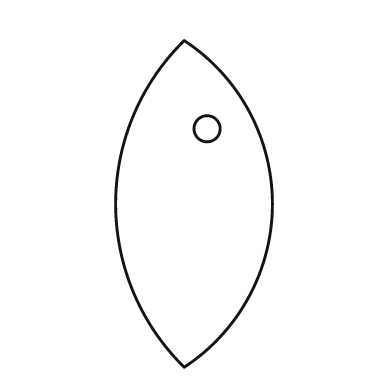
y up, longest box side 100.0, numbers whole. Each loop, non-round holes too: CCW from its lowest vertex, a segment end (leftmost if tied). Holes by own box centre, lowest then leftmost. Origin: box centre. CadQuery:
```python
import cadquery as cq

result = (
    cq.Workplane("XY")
    .moveTo(-3.0, -50.0)
    .threePointArc((24.0, 0.0), (-3.0, 50.0))
    .threePointArc((-24.0, 0.0), (-3.0, -50.0))
    .close()
    .moveTo(4.0, 23.0)
    .circle(4.0)
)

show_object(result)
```